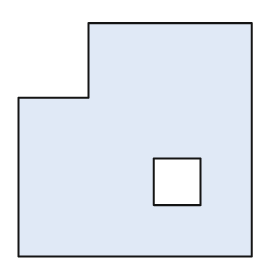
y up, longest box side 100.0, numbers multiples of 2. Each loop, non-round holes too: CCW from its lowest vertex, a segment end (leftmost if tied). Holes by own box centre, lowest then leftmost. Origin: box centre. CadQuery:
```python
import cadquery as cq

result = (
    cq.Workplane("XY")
    .moveTo(-50.0, -50.0)
    .lineTo(50.0, -50.0)
    .lineTo(50.0, 50.0)
    .lineTo(-20.0, 50.0)
    .lineTo(-20.0, 18.0)
    .lineTo(-50.0, 18.0)
    .close()
    .moveTo(8.0, -28.0)
    .lineTo(28.0, -28.0)
    .lineTo(28.0, -8.0)
    .lineTo(8.0, -8.0)
    .close()
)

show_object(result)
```